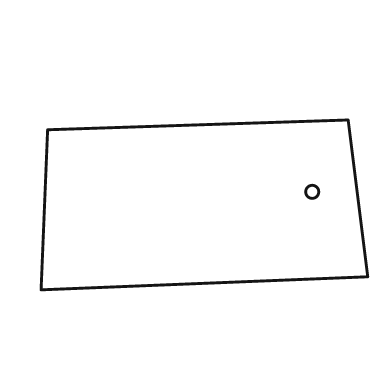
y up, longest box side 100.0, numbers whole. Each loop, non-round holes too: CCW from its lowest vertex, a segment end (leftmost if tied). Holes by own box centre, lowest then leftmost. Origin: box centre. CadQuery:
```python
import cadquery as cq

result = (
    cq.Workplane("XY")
    .moveTo(-50.0, -26.0)
    .lineTo(50.0, -22.0)
    .lineTo(44.0, 26.0)
    .lineTo(-48.0, 23.0)
    .close()
    .moveTo(33.0, 4.0)
    .circle(2.0)
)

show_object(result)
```